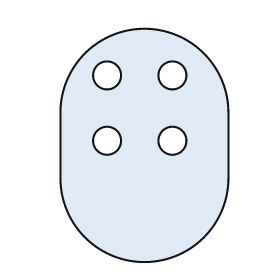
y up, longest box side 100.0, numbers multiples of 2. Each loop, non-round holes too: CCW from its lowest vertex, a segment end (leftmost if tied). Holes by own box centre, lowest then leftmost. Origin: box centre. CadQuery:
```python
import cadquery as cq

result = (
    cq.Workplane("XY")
    .moveTo(-36.0, -14.0)
    .threePointArc((0.0, -50.0), (36.0, -14.0))
    .lineTo(36.0, 14.0)
    .threePointArc((0.0, 50.0), (-36.0, 14.0))
    .close()
    .moveTo(-16.0, 2.0)
    .circle(6.0)
    .moveTo(12.0, 2.0)
    .circle(6.0)
    .moveTo(-16.0, 30.0)
    .circle(6.0)
    .moveTo(12.0, 30.0)
    .circle(6.0)
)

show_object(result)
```